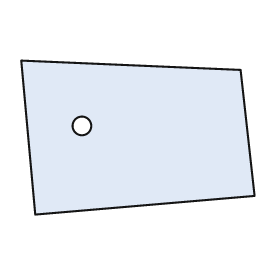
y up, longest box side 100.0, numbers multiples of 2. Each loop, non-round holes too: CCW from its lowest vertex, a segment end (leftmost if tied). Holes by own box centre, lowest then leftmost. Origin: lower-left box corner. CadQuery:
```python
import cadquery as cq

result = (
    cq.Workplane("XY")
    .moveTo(6.0, 0.0)
    .lineTo(100.0, 8.0)
    .lineTo(94.0, 62.0)
    .lineTo(0.0, 66.0)
    .close()
    .moveTo(26.0, 38.0)
    .circle(4.0)
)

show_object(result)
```